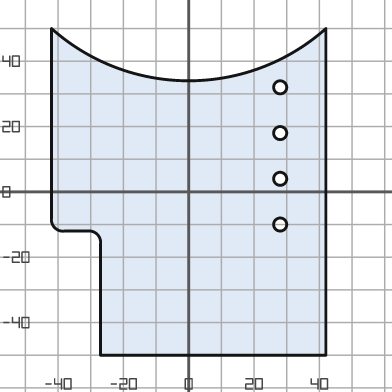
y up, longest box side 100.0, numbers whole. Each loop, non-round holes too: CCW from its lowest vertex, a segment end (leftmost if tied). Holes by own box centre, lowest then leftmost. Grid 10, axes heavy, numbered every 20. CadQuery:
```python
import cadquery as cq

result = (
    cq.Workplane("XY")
    .moveTo(-27.0, -50.0)
    .lineTo(42.0, -50.0)
    .lineTo(42.0, 50.0)
    .threePointArc((0.0, 34.0), (-42.0, 50.0))
    .lineTo(-42.0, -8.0)
    .threePointArc((-41.0, -11.0), (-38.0, -12.0))
    .lineTo(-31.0, -12.0)
    .threePointArc((-28.0, -13.0), (-27.0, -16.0))
    .close()
    .moveTo(28.0, -10.0)
    .circle(2.0)
    .moveTo(28.0, 4.0)
    .circle(2.0)
    .moveTo(28.0, 18.0)
    .circle(2.0)
    .moveTo(28.0, 32.0)
    .circle(2.0)
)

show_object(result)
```